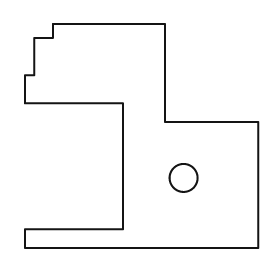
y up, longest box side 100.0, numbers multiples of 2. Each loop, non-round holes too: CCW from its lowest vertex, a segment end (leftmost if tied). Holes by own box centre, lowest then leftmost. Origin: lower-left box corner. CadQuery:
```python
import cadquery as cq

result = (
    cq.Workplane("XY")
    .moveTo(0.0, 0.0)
    .lineTo(100.0, 0.0)
    .lineTo(100.0, 54.0)
    .lineTo(60.0, 54.0)
    .lineTo(60.0, 96.0)
    .lineTo(12.0, 96.0)
    .lineTo(12.0, 90.0)
    .lineTo(4.0, 90.0)
    .lineTo(4.0, 74.0)
    .lineTo(0.0, 74.0)
    .lineTo(0.0, 62.0)
    .lineTo(42.0, 62.0)
    .lineTo(42.0, 8.0)
    .lineTo(0.0, 8.0)
    .close()
    .moveTo(68.0, 30.0)
    .circle(6.0)
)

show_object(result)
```